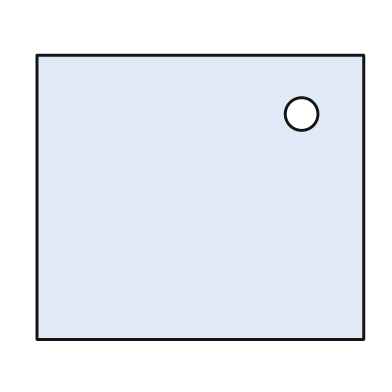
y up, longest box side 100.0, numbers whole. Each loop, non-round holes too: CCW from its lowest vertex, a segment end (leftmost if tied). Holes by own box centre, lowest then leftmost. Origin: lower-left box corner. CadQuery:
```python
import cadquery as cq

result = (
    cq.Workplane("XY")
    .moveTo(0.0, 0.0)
    .lineTo(100.0, 0.0)
    .lineTo(100.0, 87.0)
    .lineTo(0.0, 87.0)
    .close()
    .moveTo(81.0, 69.0)
    .circle(5.0)
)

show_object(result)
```